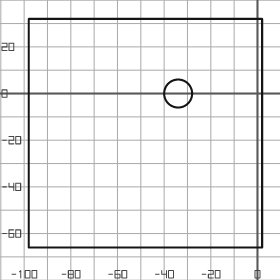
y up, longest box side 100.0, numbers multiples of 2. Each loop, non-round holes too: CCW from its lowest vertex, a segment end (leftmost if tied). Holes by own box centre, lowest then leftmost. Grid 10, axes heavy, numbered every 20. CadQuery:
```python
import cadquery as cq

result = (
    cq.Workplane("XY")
    .moveTo(-98.0, -66.0)
    .lineTo(2.0, -66.0)
    .lineTo(2.0, 32.0)
    .lineTo(-98.0, 32.0)
    .close()
    .moveTo(-34.0, 0.0)
    .circle(6.0)
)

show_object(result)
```